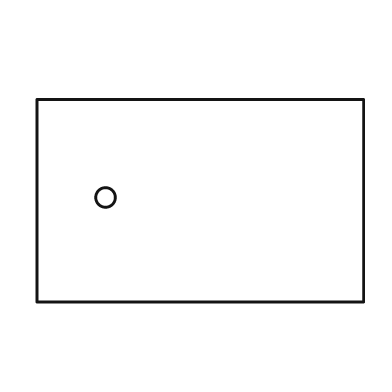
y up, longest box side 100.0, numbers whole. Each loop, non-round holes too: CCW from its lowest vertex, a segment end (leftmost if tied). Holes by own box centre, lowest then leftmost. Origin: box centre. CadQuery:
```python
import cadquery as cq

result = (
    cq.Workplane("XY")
    .moveTo(-50.0, -31.0)
    .lineTo(50.0, -31.0)
    .lineTo(50.0, 31.0)
    .lineTo(-50.0, 31.0)
    .close()
    .moveTo(-29.0, 1.0)
    .circle(3.0)
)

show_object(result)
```